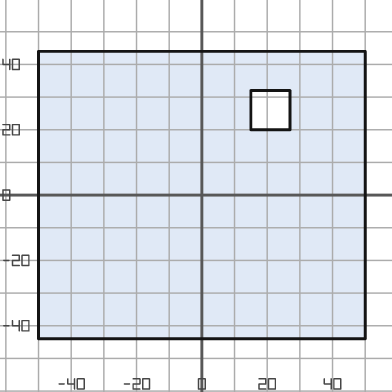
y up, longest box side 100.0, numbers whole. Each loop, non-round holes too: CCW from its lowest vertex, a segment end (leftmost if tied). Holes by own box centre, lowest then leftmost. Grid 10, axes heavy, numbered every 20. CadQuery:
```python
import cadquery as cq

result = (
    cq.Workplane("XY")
    .moveTo(-50.0, -44.0)
    .lineTo(50.0, -44.0)
    .lineTo(50.0, 44.0)
    .lineTo(-50.0, 44.0)
    .close()
    .moveTo(15.0, 20.0)
    .lineTo(27.0, 20.0)
    .lineTo(27.0, 32.0)
    .lineTo(15.0, 32.0)
    .close()
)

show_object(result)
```